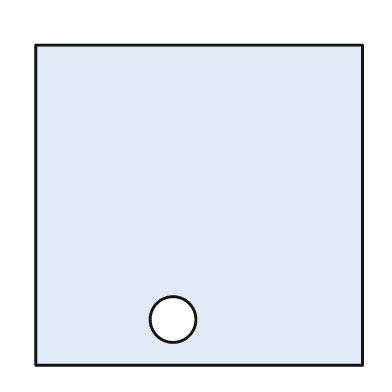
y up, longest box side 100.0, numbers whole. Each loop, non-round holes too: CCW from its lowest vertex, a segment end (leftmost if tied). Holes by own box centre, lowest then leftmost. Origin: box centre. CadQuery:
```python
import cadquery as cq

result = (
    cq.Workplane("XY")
    .moveTo(-50.0, -49.0)
    .lineTo(50.0, -49.0)
    .lineTo(50.0, 49.0)
    .lineTo(-50.0, 49.0)
    .close()
    .moveTo(-8.0, -35.0)
    .circle(7.0)
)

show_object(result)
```